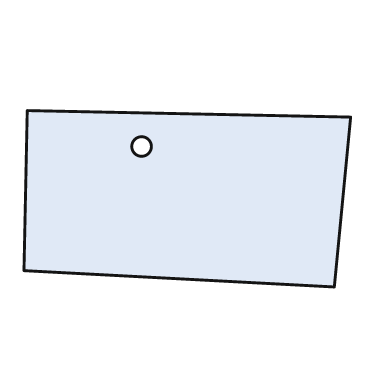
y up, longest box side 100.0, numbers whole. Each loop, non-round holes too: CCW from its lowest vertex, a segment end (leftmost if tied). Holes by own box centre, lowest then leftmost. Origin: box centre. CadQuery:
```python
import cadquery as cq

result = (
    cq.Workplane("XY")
    .moveTo(45.0, -27.0)
    .lineTo(50.0, 25.0)
    .lineTo(-49.0, 27.0)
    .lineTo(-50.0, -22.0)
    .close()
    .moveTo(-14.0, 16.0)
    .circle(3.0)
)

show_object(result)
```